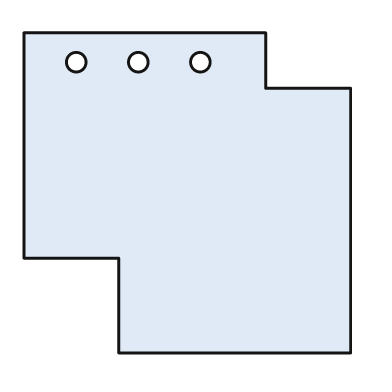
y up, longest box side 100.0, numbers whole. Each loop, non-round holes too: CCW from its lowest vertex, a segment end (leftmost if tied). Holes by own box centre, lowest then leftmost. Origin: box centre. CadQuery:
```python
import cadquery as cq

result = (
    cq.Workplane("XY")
    .moveTo(-21.0, -49.0)
    .lineTo(50.0, -49.0)
    .lineTo(50.0, 32.0)
    .lineTo(24.0, 32.0)
    .lineTo(24.0, 49.0)
    .lineTo(-50.0, 49.0)
    .lineTo(-50.0, -20.0)
    .lineTo(-21.0, -20.0)
    .close()
    .moveTo(-34.0, 40.0)
    .circle(3.0)
    .moveTo(-15.0, 40.0)
    .circle(3.0)
    .moveTo(4.0, 40.0)
    .circle(3.0)
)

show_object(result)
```